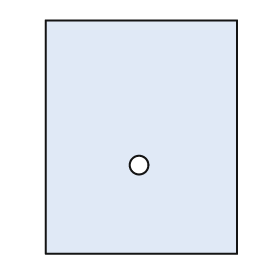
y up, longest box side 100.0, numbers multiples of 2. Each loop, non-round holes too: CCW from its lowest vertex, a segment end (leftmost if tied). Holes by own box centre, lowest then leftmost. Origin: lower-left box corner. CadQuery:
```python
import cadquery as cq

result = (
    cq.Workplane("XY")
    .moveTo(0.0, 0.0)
    .lineTo(82.0, 0.0)
    .lineTo(82.0, 100.0)
    .lineTo(0.0, 100.0)
    .close()
    .moveTo(40.0, 38.0)
    .circle(4.0)
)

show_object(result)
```